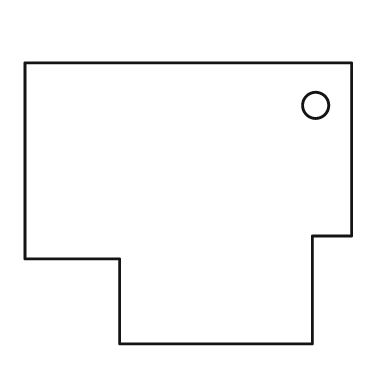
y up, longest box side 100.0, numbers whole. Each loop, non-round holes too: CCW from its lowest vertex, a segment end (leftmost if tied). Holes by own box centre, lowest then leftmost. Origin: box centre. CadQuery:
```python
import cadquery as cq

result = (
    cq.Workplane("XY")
    .moveTo(-21.0, -43.0)
    .lineTo(38.0, -43.0)
    .lineTo(38.0, -10.0)
    .lineTo(50.0, -10.0)
    .lineTo(50.0, 43.0)
    .lineTo(-50.0, 43.0)
    .lineTo(-50.0, -17.0)
    .lineTo(-21.0, -17.0)
    .close()
    .moveTo(39.0, 30.0)
    .circle(4.0)
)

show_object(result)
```